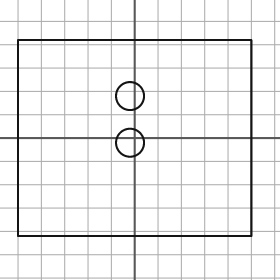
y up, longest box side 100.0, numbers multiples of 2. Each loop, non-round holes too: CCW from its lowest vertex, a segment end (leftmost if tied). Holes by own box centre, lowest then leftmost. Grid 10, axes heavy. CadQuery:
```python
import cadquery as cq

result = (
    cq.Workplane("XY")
    .moveTo(-50.0, -42.0)
    .lineTo(50.0, -42.0)
    .lineTo(50.0, 42.0)
    .lineTo(-50.0, 42.0)
    .close()
    .moveTo(-2.0, -2.0)
    .circle(6.0)
    .moveTo(-2.0, 18.0)
    .circle(6.0)
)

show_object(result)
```